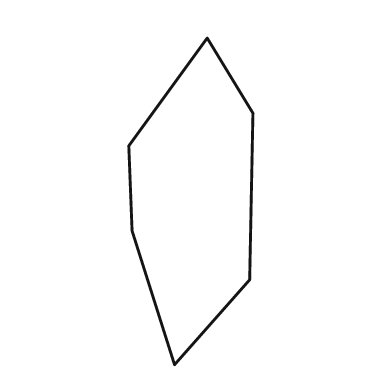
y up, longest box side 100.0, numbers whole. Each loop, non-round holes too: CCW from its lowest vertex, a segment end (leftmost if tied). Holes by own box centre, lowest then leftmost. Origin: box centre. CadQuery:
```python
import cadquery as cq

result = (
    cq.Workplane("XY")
    .moveTo(-5.0, -50.0)
    .lineTo(18.0, -24.0)
    .lineTo(19.0, 27.0)
    .lineTo(5.0, 50.0)
    .lineTo(-19.0, 17.0)
    .lineTo(-18.0, -9.0)
    .close()
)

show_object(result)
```